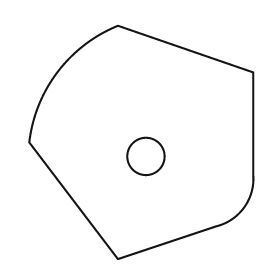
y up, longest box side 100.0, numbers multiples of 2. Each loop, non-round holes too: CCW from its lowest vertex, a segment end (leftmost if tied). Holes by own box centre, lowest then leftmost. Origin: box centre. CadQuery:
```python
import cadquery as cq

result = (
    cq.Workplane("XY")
    .moveTo(-10.0, -50.0)
    .lineTo(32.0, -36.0)
    .threePointArc((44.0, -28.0), (48.0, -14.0))
    .lineTo(48.0, 30.0)
    .lineTo(-10.0, 50.0)
    .threePointArc((-36.0, 30.0), (-48.0, 0.0))
    .close()
    .moveTo(2.0, -6.0)
    .circle(8.0)
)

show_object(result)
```